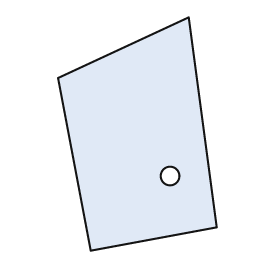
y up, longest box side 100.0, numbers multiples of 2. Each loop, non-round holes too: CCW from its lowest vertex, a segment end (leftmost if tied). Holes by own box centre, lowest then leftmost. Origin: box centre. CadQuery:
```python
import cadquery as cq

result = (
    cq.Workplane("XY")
    .moveTo(-20.0, -50.0)
    .lineTo(34.0, -40.0)
    .lineTo(22.0, 50.0)
    .lineTo(-34.0, 24.0)
    .close()
    .moveTo(14.0, -18.0)
    .circle(4.0)
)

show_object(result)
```